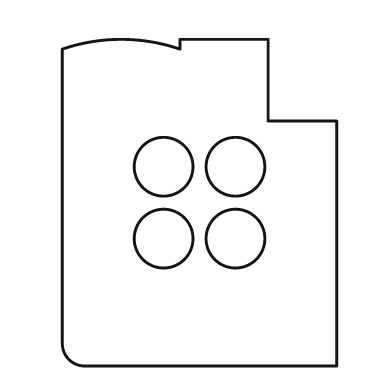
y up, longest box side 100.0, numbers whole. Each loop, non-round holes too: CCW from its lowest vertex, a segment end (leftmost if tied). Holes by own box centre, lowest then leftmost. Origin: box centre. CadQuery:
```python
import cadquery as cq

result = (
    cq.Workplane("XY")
    .moveTo(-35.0, -50.0)
    .lineTo(42.0, -50.0)
    .lineTo(42.0, 25.0)
    .lineTo(21.0, 25.0)
    .lineTo(21.0, 50.0)
    .lineTo(-6.0, 50.0)
    .lineTo(-6.0, 47.0)
    .threePointArc((-24.0, 50.0), (-42.0, 47.0))
    .lineTo(-42.0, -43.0)
    .threePointArc((-40.0, -48.0), (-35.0, -50.0))
    .close()
    .moveTo(-11.0, -11.0)
    .circle(9.0)
    .moveTo(11.0, -11.0)
    .circle(9.0)
    .moveTo(-11.0, 11.0)
    .circle(9.0)
    .moveTo(11.0, 11.0)
    .circle(9.0)
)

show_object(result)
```